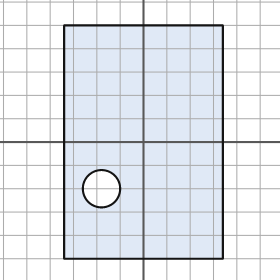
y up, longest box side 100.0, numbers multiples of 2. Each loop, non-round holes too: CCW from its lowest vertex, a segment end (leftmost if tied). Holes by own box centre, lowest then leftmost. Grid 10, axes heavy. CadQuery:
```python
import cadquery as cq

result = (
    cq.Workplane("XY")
    .moveTo(-34.0, -50.0)
    .lineTo(34.0, -50.0)
    .lineTo(34.0, 50.0)
    .lineTo(-34.0, 50.0)
    .close()
    .moveTo(-18.0, -20.0)
    .circle(8.0)
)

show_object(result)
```